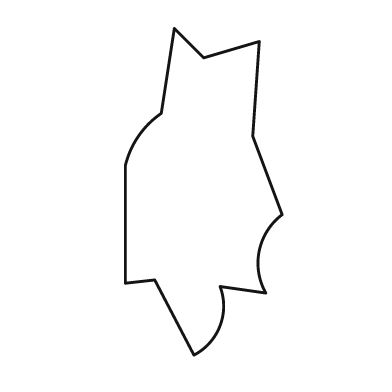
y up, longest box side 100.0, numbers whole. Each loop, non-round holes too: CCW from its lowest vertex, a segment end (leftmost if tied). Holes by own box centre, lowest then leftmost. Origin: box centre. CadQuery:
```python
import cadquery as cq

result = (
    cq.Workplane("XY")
    .moveTo(-3.0, -50.0)
    .threePointArc((5.0, -41.0), (5.0, -29.0))
    .lineTo(19.0, -31.0)
    .threePointArc((17.0, -18.0), (24.0, -7.0))
    .lineTo(15.0, 17.0)
    .lineTo(17.0, 46.0)
    .lineTo(0.0, 41.0)
    .lineTo(-9.0, 50.0)
    .lineTo(-13.0, 24.0)
    .threePointArc((-20.0, 17.0), (-24.0, 8.0))
    .lineTo(-24.0, -28.0)
    .lineTo(-15.0, -27.0)
    .close()
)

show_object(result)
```